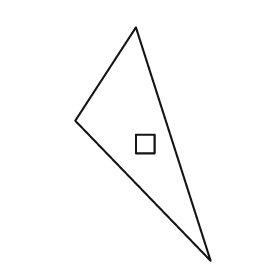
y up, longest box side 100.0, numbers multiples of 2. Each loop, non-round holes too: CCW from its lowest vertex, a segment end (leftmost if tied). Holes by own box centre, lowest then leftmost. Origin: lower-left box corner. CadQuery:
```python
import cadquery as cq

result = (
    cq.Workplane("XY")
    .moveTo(58.0, 0.0)
    .lineTo(26.0, 100.0)
    .lineTo(0.0, 60.0)
    .close()
    .moveTo(26.0, 46.0)
    .lineTo(34.0, 46.0)
    .lineTo(34.0, 54.0)
    .lineTo(26.0, 54.0)
    .close()
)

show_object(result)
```